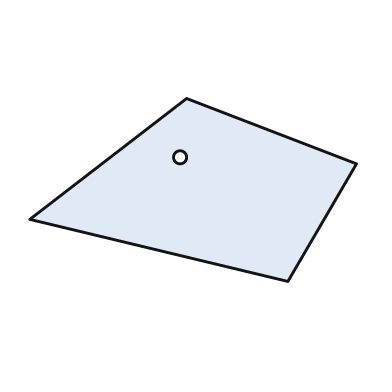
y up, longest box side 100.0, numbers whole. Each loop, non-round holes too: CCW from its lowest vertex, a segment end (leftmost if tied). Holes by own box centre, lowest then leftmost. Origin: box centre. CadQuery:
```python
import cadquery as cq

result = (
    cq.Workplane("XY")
    .moveTo(29.0, -28.0)
    .lineTo(50.0, 8.0)
    .lineTo(-2.0, 28.0)
    .lineTo(-50.0, -9.0)
    .close()
    .moveTo(-4.0, 10.0)
    .circle(2.0)
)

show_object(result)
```